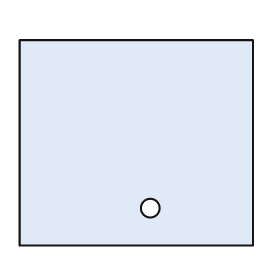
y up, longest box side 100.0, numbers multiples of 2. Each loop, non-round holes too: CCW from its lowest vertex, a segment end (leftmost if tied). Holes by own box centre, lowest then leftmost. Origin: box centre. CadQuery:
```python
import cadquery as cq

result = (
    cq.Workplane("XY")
    .moveTo(-50.0, -44.0)
    .lineTo(50.0, -44.0)
    .lineTo(50.0, 44.0)
    .lineTo(-50.0, 44.0)
    .close()
    .moveTo(6.0, -28.0)
    .circle(4.0)
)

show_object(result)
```